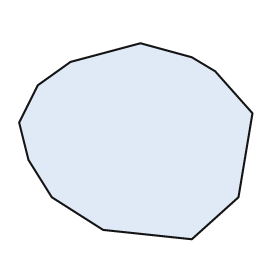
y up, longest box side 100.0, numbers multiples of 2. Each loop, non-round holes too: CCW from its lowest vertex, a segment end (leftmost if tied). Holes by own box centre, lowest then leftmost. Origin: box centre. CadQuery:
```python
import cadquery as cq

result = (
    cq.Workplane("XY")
    .moveTo(24.0, -42.0)
    .lineTo(44.0, -24.0)
    .lineTo(50.0, 12.0)
    .lineTo(34.0, 30.0)
    .lineTo(24.0, 36.0)
    .lineTo(2.0, 42.0)
    .lineTo(-28.0, 34.0)
    .lineTo(-42.0, 24.0)
    .lineTo(-50.0, 8.0)
    .lineTo(-46.0, -8.0)
    .lineTo(-36.0, -24.0)
    .lineTo(-14.0, -38.0)
    .close()
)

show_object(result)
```